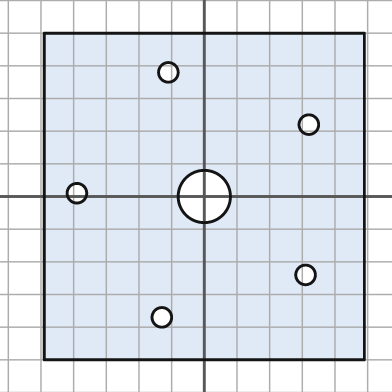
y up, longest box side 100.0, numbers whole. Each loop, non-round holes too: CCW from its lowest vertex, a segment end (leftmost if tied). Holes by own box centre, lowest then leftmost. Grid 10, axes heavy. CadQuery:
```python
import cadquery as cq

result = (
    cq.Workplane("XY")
    .moveTo(-49.0, -50.0)
    .lineTo(49.0, -50.0)
    .lineTo(49.0, 50.0)
    .lineTo(-49.0, 50.0)
    .close()
    .moveTo(-13.0, -37.0)
    .circle(3.0)
    .moveTo(31.0, -24.0)
    .circle(3.0)
    .moveTo(0.0, 0.0)
    .circle(8.0)
    .moveTo(-39.0, 1.0)
    .circle(3.0)
    .moveTo(32.0, 22.0)
    .circle(3.0)
    .moveTo(-11.0, 38.0)
    .circle(3.0)
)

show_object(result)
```